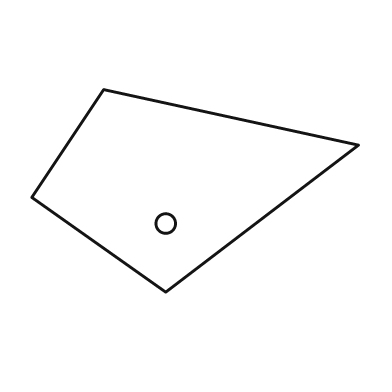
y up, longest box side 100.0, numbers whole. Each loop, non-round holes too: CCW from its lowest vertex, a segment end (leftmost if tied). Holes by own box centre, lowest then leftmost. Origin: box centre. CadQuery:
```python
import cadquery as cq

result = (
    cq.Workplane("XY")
    .moveTo(-9.0, -31.0)
    .lineTo(50.0, 14.0)
    .lineTo(-28.0, 31.0)
    .lineTo(-50.0, -2.0)
    .close()
    .moveTo(-9.0, -10.0)
    .circle(3.0)
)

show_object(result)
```